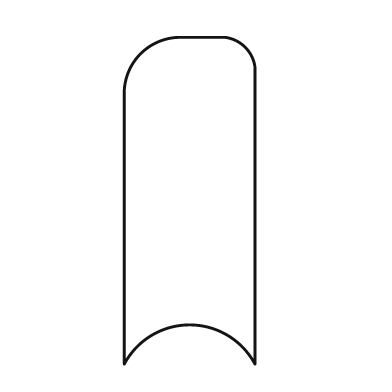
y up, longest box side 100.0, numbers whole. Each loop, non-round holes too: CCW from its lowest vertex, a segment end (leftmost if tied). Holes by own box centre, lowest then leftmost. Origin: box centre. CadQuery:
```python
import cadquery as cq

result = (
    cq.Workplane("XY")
    .moveTo(-20.0, -50.0)
    .threePointArc((0.0, -38.0), (20.0, -50.0))
    .lineTo(20.0, 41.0)
    .threePointArc((17.0, 47.0), (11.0, 50.0))
    .lineTo(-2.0, 50.0)
    .threePointArc((-15.0, 45.0), (-20.0, 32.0))
    .close()
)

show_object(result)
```